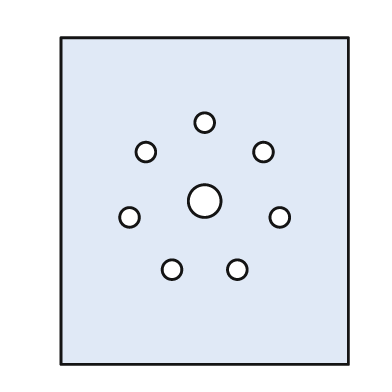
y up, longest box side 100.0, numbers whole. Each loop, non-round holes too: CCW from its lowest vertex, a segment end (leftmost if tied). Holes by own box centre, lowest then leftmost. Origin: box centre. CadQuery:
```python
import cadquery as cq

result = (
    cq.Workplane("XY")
    .moveTo(-44.0, -50.0)
    .lineTo(44.0, -50.0)
    .lineTo(44.0, 50.0)
    .lineTo(-44.0, 50.0)
    .close()
    .moveTo(-10.0, -21.0)
    .circle(3.0)
    .moveTo(10.0, -21.0)
    .circle(3.0)
    .moveTo(-23.0, -5.0)
    .circle(3.0)
    .moveTo(23.0, -5.0)
    .circle(3.0)
    .moveTo(0.0, 0.0)
    .circle(5.0)
    .moveTo(-18.0, 15.0)
    .circle(3.0)
    .moveTo(18.0, 15.0)
    .circle(3.0)
    .moveTo(0.0, 24.0)
    .circle(3.0)
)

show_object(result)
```